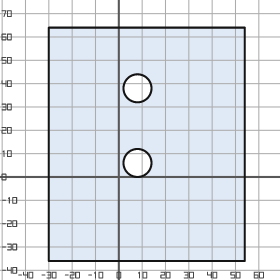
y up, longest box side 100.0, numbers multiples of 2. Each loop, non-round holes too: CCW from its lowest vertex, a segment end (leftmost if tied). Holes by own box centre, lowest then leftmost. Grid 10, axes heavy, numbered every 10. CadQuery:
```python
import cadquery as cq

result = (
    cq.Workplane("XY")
    .moveTo(-30.0, -36.0)
    .lineTo(54.0, -36.0)
    .lineTo(54.0, 64.0)
    .lineTo(-30.0, 64.0)
    .close()
    .moveTo(8.0, 6.0)
    .circle(6.0)
    .moveTo(8.0, 38.0)
    .circle(6.0)
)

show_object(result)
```